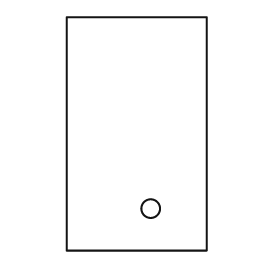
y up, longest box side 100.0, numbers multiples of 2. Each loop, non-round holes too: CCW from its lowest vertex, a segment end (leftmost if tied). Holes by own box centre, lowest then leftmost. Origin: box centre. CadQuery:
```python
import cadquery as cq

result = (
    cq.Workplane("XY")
    .moveTo(-30.0, -50.0)
    .lineTo(30.0, -50.0)
    .lineTo(30.0, 50.0)
    .lineTo(-30.0, 50.0)
    .close()
    .moveTo(6.0, -32.0)
    .circle(4.0)
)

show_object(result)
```